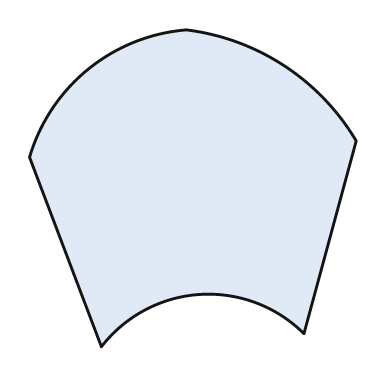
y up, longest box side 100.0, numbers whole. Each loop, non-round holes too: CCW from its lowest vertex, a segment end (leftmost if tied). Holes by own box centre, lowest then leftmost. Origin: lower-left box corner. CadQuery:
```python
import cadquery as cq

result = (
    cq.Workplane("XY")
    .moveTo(22.0, 0.0)
    .threePointArc((52.0, 16.0), (84.0, 4.0))
    .lineTo(100.0, 63.0)
    .threePointArc((78.0, 86.0), (48.0, 97.0))
    .threePointArc((18.0, 85.0), (0.0, 58.0))
    .close()
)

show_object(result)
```